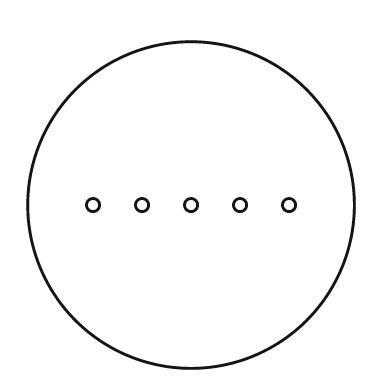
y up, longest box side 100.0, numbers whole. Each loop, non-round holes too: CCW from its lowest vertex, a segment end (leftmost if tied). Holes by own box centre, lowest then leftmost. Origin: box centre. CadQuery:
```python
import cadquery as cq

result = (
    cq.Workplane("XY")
    .moveTo(0.0, 0.0)
    .circle(50.0)
    .moveTo(-30.0, 0.0)
    .circle(2.0)
    .moveTo(-15.0, 0.0)
    .circle(2.0)
    .moveTo(0.0, 0.0)
    .circle(2.0)
    .moveTo(15.0, 0.0)
    .circle(2.0)
    .moveTo(30.0, 0.0)
    .circle(2.0)
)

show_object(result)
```